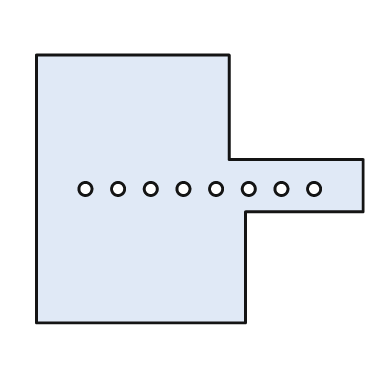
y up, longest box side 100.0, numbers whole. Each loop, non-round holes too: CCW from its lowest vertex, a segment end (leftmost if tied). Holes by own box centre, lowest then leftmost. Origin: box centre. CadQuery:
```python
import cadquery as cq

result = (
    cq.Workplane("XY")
    .moveTo(-50.0, -41.0)
    .lineTo(14.0, -41.0)
    .lineTo(14.0, -7.0)
    .lineTo(50.0, -7.0)
    .lineTo(50.0, 9.0)
    .lineTo(9.0, 9.0)
    .lineTo(9.0, 41.0)
    .lineTo(-50.0, 41.0)
    .close()
    .moveTo(-35.0, 0.0)
    .circle(2.0)
    .moveTo(-25.0, 0.0)
    .circle(2.0)
    .moveTo(-15.0, 0.0)
    .circle(2.0)
    .moveTo(-5.0, 0.0)
    .circle(2.0)
    .moveTo(5.0, 0.0)
    .circle(2.0)
    .moveTo(15.0, 0.0)
    .circle(2.0)
    .moveTo(25.0, 0.0)
    .circle(2.0)
    .moveTo(35.0, 0.0)
    .circle(2.0)
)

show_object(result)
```